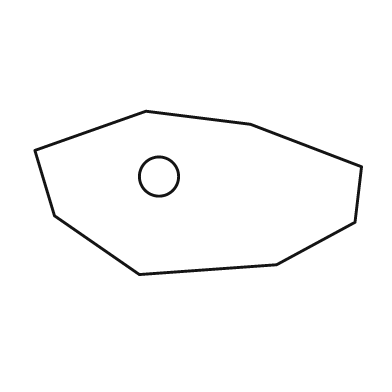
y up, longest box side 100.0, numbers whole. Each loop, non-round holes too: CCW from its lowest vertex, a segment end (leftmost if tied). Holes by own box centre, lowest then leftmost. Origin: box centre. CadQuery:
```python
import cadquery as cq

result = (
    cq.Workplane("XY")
    .moveTo(-18.0, -25.0)
    .lineTo(24.0, -22.0)
    .lineTo(48.0, -9.0)
    .lineTo(50.0, 8.0)
    .lineTo(16.0, 21.0)
    .lineTo(-16.0, 25.0)
    .lineTo(-50.0, 13.0)
    .lineTo(-44.0, -7.0)
    .close()
    .moveTo(-12.0, 5.0)
    .circle(6.0)
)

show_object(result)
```